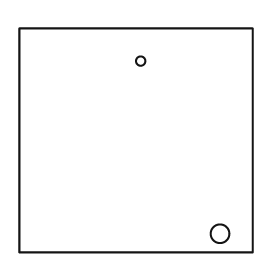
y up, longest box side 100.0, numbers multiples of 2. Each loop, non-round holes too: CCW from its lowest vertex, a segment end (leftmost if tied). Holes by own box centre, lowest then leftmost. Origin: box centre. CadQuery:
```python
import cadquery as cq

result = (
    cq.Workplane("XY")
    .moveTo(-50.0, -48.0)
    .lineTo(50.0, -48.0)
    .lineTo(50.0, 48.0)
    .lineTo(-50.0, 48.0)
    .close()
    .moveTo(36.0, -40.0)
    .circle(4.0)
    .moveTo(2.0, 34.0)
    .circle(2.0)
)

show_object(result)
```